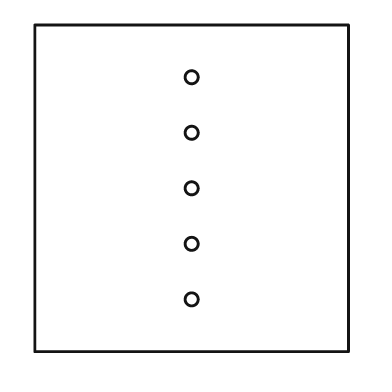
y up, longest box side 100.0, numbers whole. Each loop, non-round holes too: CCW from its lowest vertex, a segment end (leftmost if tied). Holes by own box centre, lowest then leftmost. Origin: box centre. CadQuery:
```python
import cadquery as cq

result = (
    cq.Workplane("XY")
    .moveTo(-48.0, -50.0)
    .lineTo(48.0, -50.0)
    .lineTo(48.0, 50.0)
    .lineTo(-48.0, 50.0)
    .close()
    .moveTo(0.0, -34.0)
    .circle(2.0)
    .moveTo(0.0, -17.0)
    .circle(2.0)
    .moveTo(0.0, 0.0)
    .circle(2.0)
    .moveTo(0.0, 17.0)
    .circle(2.0)
    .moveTo(0.0, 34.0)
    .circle(2.0)
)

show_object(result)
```